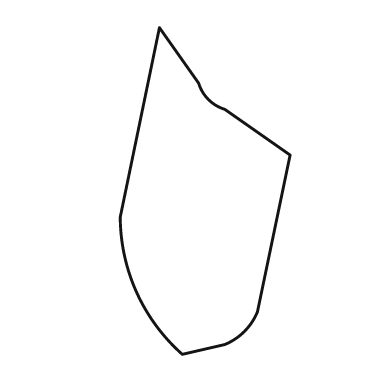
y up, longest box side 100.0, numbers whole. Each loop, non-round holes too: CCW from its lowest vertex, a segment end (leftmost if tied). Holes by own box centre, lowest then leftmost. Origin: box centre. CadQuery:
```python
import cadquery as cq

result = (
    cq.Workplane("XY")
    .moveTo(-7.0, -50.0)
    .lineTo(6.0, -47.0)
    .threePointArc((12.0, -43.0), (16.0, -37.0))
    .lineTo(26.0, 11.0)
    .lineTo(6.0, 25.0)
    .threePointArc((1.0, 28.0), (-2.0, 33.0))
    .lineTo(-14.0, 50.0)
    .lineTo(-26.0, -8.0)
    .threePointArc((-21.0, -31.0), (-7.0, -50.0))
    .close()
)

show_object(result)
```